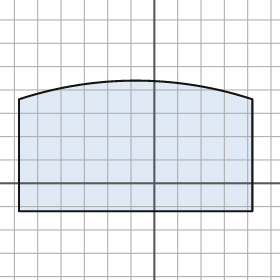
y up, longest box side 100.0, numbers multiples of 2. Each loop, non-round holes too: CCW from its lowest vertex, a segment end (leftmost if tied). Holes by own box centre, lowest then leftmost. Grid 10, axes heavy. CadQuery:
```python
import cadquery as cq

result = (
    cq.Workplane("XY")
    .moveTo(-58.0, -12.0)
    .lineTo(42.0, -12.0)
    .lineTo(42.0, 36.0)
    .threePointArc((-8.0, 44.0), (-58.0, 36.0))
    .close()
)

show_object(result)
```